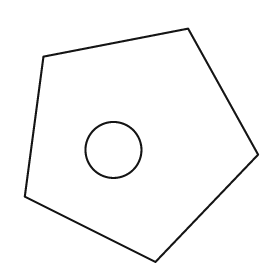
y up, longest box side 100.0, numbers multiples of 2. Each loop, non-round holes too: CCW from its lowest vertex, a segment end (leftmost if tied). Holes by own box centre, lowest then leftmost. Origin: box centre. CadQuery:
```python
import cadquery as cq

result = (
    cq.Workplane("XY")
    .moveTo(6.0, -50.0)
    .lineTo(50.0, -4.0)
    .lineTo(20.0, 50.0)
    .lineTo(-42.0, 38.0)
    .lineTo(-50.0, -22.0)
    .close()
    .moveTo(-12.0, -2.0)
    .circle(12.0)
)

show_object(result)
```